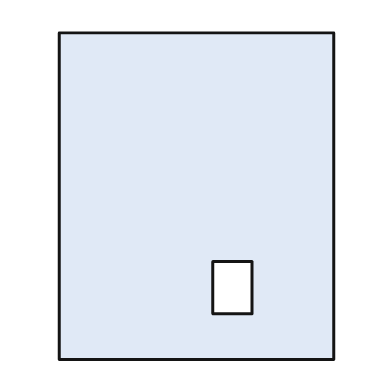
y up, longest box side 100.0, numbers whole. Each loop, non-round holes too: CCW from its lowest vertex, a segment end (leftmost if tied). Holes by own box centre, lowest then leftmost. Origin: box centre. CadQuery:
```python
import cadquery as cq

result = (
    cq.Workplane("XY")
    .moveTo(-42.0, -50.0)
    .lineTo(42.0, -50.0)
    .lineTo(42.0, 50.0)
    .lineTo(-42.0, 50.0)
    .close()
    .moveTo(5.0, -36.0)
    .lineTo(17.0, -36.0)
    .lineTo(17.0, -20.0)
    .lineTo(5.0, -20.0)
    .close()
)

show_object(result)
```